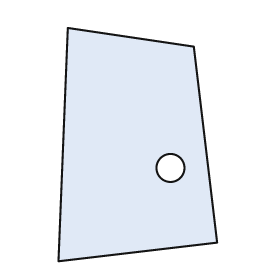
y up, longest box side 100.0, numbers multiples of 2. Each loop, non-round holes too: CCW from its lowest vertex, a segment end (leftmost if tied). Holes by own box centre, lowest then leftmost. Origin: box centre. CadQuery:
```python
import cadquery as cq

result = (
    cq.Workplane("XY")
    .moveTo(-34.0, -50.0)
    .lineTo(34.0, -42.0)
    .lineTo(24.0, 42.0)
    .lineTo(-30.0, 50.0)
    .close()
    .moveTo(14.0, -10.0)
    .circle(6.0)
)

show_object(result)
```